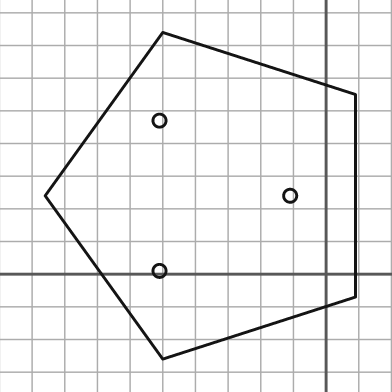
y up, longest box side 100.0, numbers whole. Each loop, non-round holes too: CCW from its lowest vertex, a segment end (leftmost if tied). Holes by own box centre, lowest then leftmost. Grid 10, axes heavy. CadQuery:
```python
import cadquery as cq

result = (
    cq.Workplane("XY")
    .moveTo(-50.0, -26.0)
    .lineTo(9.0, -7.0)
    .lineTo(9.0, 55.0)
    .lineTo(-50.0, 74.0)
    .lineTo(-86.0, 24.0)
    .close()
    .moveTo(-51.0, 1.0)
    .circle(2.0)
    .moveTo(-11.0, 24.0)
    .circle(2.0)
    .moveTo(-51.0, 47.0)
    .circle(2.0)
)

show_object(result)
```